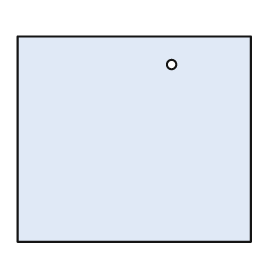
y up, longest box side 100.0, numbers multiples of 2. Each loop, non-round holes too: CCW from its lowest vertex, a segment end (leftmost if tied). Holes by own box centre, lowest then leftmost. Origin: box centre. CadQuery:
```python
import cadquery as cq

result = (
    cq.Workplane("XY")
    .moveTo(-50.0, -44.0)
    .lineTo(50.0, -44.0)
    .lineTo(50.0, 44.0)
    .lineTo(-50.0, 44.0)
    .close()
    .moveTo(16.0, 32.0)
    .circle(2.0)
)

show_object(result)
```